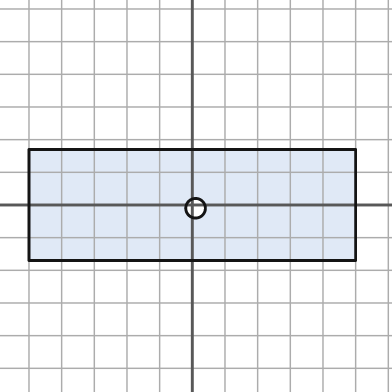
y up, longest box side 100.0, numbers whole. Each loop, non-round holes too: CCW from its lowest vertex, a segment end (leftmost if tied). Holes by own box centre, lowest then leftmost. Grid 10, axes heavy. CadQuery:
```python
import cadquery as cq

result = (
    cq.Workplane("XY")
    .moveTo(-50.0, -17.0)
    .lineTo(50.0, -17.0)
    .lineTo(50.0, 17.0)
    .lineTo(-50.0, 17.0)
    .close()
    .moveTo(1.0, -1.0)
    .circle(3.0)
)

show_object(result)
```